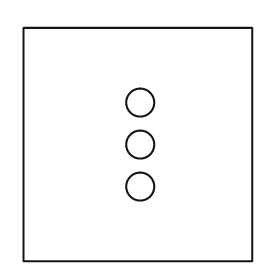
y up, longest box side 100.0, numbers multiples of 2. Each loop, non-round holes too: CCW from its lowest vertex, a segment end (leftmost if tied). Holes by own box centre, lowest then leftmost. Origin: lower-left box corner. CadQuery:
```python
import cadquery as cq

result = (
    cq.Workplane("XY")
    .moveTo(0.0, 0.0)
    .lineTo(98.0, 0.0)
    .lineTo(98.0, 100.0)
    .lineTo(0.0, 100.0)
    .close()
    .moveTo(50.0, 32.0)
    .circle(6.0)
    .moveTo(50.0, 50.0)
    .circle(6.0)
    .moveTo(50.0, 68.0)
    .circle(6.0)
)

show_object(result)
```